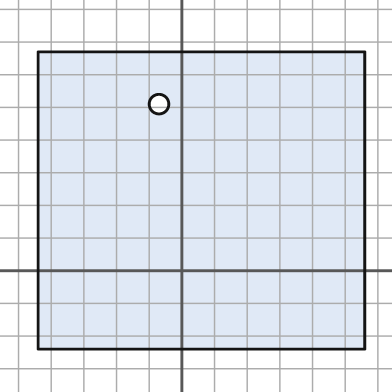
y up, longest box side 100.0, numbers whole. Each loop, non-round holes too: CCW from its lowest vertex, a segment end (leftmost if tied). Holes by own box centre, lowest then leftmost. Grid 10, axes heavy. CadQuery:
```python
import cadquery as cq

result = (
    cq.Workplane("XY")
    .moveTo(-44.0, -24.0)
    .lineTo(56.0, -24.0)
    .lineTo(56.0, 67.0)
    .lineTo(-44.0, 67.0)
    .close()
    .moveTo(-7.0, 51.0)
    .circle(3.0)
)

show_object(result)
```